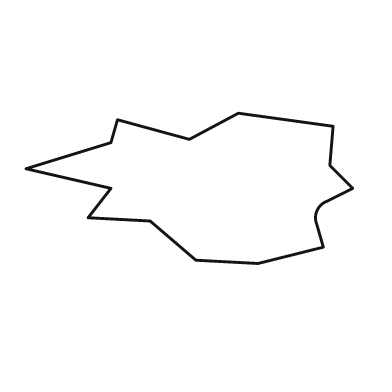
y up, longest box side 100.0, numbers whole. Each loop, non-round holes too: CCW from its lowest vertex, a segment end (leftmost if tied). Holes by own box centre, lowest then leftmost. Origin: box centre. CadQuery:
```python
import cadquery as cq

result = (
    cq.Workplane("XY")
    .moveTo(21.0, -23.0)
    .lineTo(41.0, -18.0)
    .lineTo(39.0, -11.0)
    .threePointArc((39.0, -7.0), (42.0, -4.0))
    .lineTo(50.0, 0.0)
    .lineTo(43.0, 7.0)
    .lineTo(44.0, 19.0)
    .lineTo(15.0, 23.0)
    .lineTo(0.0, 15.0)
    .lineTo(-22.0, 21.0)
    .lineTo(-24.0, 14.0)
    .lineTo(-50.0, 6.0)
    .lineTo(-24.0, 0.0)
    .lineTo(-31.0, -9.0)
    .lineTo(-12.0, -10.0)
    .lineTo(2.0, -22.0)
    .close()
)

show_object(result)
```